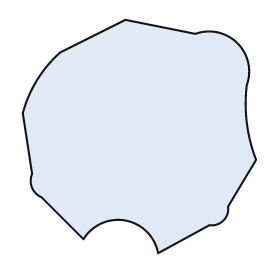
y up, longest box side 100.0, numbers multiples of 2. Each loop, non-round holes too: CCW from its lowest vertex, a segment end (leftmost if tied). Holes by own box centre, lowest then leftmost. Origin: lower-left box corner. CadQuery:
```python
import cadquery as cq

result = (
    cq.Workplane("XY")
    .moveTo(58.0, 0.0)
    .lineTo(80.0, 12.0)
    .threePointArc((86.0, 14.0), (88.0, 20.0))
    .lineTo(100.0, 40.0)
    .threePointArc((96.0, 56.0), (96.0, 72.0))
    .threePointArc((92.0, 90.0), (74.0, 94.0))
    .lineTo(44.0, 100.0)
    .lineTo(16.0, 86.0)
    .threePointArc((6.0, 74.0), (0.0, 60.0))
    .lineTo(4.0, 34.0)
    .threePointArc((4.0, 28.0), (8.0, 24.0))
    .lineTo(26.0, 6.0)
    .threePointArc((44.0, 14.0), (58.0, 0.0))
    .close()
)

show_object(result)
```